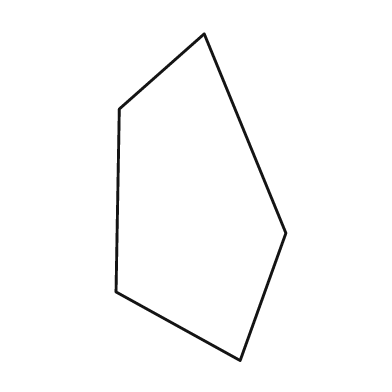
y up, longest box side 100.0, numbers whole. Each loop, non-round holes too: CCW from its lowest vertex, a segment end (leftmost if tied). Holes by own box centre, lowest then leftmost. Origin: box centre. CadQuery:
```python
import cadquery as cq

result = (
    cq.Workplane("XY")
    .moveTo(12.0, -50.0)
    .lineTo(26.0, -11.0)
    .lineTo(1.0, 50.0)
    .lineTo(-25.0, 27.0)
    .lineTo(-26.0, -29.0)
    .close()
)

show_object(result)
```